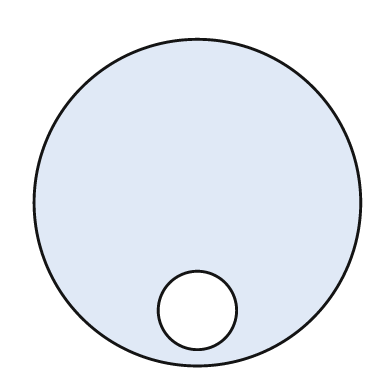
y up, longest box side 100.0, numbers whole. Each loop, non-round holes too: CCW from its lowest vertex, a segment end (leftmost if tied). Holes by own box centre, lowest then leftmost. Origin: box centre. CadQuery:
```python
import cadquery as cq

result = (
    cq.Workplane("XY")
    .moveTo(0.0, 0.0)
    .circle(50.0)
    .moveTo(0.0, -33.0)
    .circle(12.0)
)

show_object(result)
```